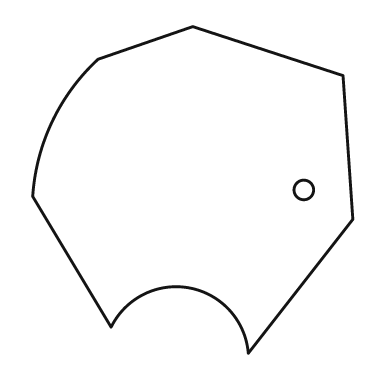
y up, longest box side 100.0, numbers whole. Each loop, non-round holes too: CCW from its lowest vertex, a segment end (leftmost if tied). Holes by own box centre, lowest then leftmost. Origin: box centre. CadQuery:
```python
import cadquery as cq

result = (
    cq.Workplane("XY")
    .moveTo(17.0, -50.0)
    .lineTo(49.0, -9.0)
    .lineTo(46.0, 35.0)
    .lineTo(0.0, 50.0)
    .lineTo(-29.0, 40.0)
    .threePointArc((-43.0, 21.0), (-49.0, -2.0))
    .lineTo(-25.0, -42.0)
    .threePointArc((-1.0, -30.0), (17.0, -50.0))
    .close()
    .moveTo(34.0, 0.0)
    .circle(3.0)
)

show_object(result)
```